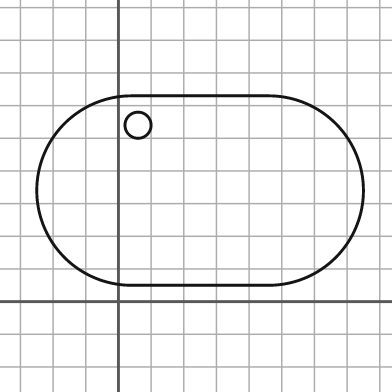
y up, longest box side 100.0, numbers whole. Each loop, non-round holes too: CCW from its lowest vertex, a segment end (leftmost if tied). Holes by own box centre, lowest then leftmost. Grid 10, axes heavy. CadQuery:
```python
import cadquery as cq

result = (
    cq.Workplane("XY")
    .moveTo(4.0, 5.0)
    .lineTo(46.0, 5.0)
    .threePointArc((75.0, 34.0), (46.0, 63.0))
    .lineTo(4.0, 63.0)
    .threePointArc((-25.0, 34.0), (4.0, 5.0))
    .close()
    .moveTo(6.0, 54.0)
    .circle(4.0)
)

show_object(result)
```